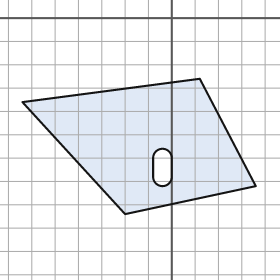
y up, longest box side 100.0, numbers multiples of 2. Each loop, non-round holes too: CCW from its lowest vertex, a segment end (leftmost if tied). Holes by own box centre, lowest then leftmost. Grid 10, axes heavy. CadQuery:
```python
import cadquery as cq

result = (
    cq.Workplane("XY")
    .moveTo(-20.0, -84.0)
    .lineTo(36.0, -72.0)
    .lineTo(12.0, -26.0)
    .lineTo(-64.0, -36.0)
    .close()
    .moveTo(-8.0, -68.0)
    .threePointArc((-4.0, -72.0), (0.0, -68.0))
    .lineTo(0.0, -60.0)
    .threePointArc((-4.0, -56.0), (-8.0, -60.0))
    .close()
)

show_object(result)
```